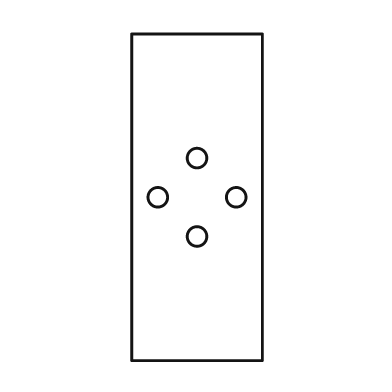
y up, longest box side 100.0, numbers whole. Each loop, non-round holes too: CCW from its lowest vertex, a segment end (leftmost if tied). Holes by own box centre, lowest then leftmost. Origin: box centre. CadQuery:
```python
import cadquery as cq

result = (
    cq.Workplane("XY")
    .moveTo(-20.0, -50.0)
    .lineTo(20.0, -50.0)
    .lineTo(20.0, 50.0)
    .lineTo(-20.0, 50.0)
    .close()
    .moveTo(0.0, -12.0)
    .circle(3.0)
    .moveTo(-12.0, 0.0)
    .circle(3.0)
    .moveTo(12.0, 0.0)
    .circle(3.0)
    .moveTo(0.0, 12.0)
    .circle(3.0)
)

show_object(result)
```